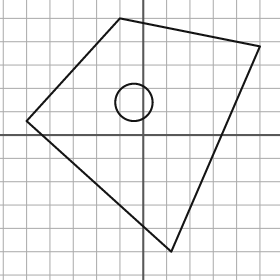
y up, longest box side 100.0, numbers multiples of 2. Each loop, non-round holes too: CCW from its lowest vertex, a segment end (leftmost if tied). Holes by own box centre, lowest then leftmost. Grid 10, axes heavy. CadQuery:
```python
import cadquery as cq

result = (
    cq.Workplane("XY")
    .moveTo(12.0, -50.0)
    .lineTo(50.0, 38.0)
    .lineTo(-10.0, 50.0)
    .lineTo(-50.0, 6.0)
    .close()
    .moveTo(-4.0, 14.0)
    .circle(8.0)
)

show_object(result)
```